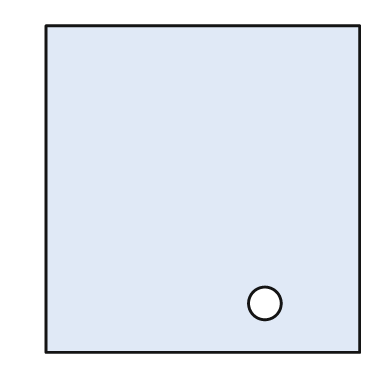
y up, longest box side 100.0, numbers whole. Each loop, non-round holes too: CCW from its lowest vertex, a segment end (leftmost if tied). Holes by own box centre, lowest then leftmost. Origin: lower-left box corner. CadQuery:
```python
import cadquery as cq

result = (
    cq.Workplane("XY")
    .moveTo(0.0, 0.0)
    .lineTo(96.0, 0.0)
    .lineTo(96.0, 100.0)
    .lineTo(0.0, 100.0)
    .close()
    .moveTo(67.0, 15.0)
    .circle(5.0)
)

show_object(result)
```